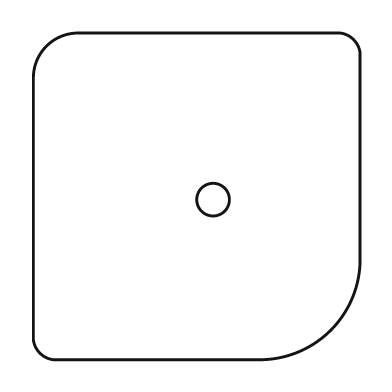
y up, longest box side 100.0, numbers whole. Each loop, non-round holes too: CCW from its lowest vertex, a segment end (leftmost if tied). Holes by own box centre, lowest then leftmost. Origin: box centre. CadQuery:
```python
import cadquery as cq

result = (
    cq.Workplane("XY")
    .moveTo(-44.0, -50.0)
    .lineTo(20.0, -50.0)
    .threePointArc((41.0, -41.0), (50.0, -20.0))
    .lineTo(50.0, 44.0)
    .threePointArc((48.0, 48.0), (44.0, 50.0))
    .lineTo(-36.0, 50.0)
    .threePointArc((-46.0, 46.0), (-50.0, 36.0))
    .lineTo(-50.0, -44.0)
    .threePointArc((-48.0, -48.0), (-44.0, -50.0))
    .close()
    .moveTo(5.0, -1.0)
    .circle(5.0)
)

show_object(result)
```